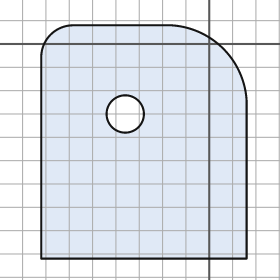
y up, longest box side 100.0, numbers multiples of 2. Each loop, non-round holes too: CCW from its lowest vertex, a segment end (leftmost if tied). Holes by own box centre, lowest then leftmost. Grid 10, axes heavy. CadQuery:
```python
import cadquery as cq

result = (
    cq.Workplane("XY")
    .moveTo(-72.0, -92.0)
    .lineTo(16.0, -92.0)
    .lineTo(16.0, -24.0)
    .threePointArc((6.0, -2.0), (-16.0, 8.0))
    .lineTo(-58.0, 8.0)
    .threePointArc((-68.0, 4.0), (-72.0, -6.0))
    .close()
    .moveTo(-36.0, -30.0)
    .circle(8.0)
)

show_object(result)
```